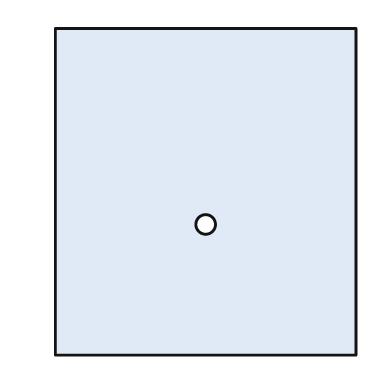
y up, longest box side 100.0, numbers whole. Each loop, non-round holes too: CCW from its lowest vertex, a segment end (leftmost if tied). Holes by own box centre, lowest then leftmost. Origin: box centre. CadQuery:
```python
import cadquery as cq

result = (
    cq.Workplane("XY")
    .moveTo(-46.0, -50.0)
    .lineTo(46.0, -50.0)
    .lineTo(46.0, 50.0)
    .lineTo(-46.0, 50.0)
    .close()
    .moveTo(0.0, -10.0)
    .circle(3.0)
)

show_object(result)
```